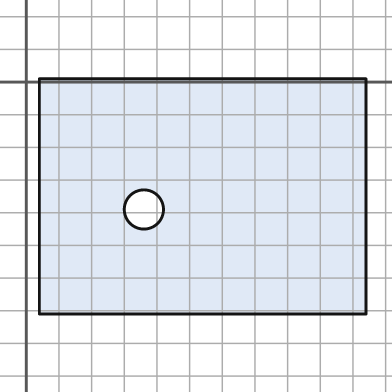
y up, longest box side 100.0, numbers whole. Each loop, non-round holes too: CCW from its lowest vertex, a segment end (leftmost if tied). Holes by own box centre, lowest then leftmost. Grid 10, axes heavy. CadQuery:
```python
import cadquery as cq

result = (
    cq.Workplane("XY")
    .moveTo(4.0, -71.0)
    .lineTo(104.0, -71.0)
    .lineTo(104.0, 1.0)
    .lineTo(4.0, 1.0)
    .close()
    .moveTo(36.0, -39.0)
    .circle(6.0)
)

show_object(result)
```